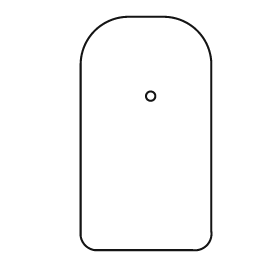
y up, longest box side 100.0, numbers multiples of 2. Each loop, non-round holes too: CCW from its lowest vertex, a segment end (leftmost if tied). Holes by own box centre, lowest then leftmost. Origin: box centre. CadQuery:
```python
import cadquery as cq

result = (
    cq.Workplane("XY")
    .moveTo(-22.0, -50.0)
    .lineTo(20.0, -50.0)
    .threePointArc((26.0, -48.0), (28.0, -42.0))
    .lineTo(28.0, 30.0)
    .threePointArc((22.0, 44.0), (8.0, 50.0))
    .lineTo(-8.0, 50.0)
    .threePointArc((-22.0, 44.0), (-28.0, 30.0))
    .lineTo(-28.0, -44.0)
    .threePointArc((-26.0, -48.0), (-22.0, -50.0))
    .close()
    .moveTo(2.0, 16.0)
    .circle(2.0)
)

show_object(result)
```